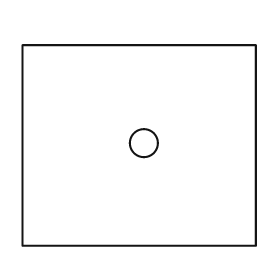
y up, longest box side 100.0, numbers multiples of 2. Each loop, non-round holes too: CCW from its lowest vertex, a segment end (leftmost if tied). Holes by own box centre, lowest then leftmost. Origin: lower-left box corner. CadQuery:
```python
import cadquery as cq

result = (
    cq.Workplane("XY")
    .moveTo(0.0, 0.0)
    .lineTo(100.0, 0.0)
    .lineTo(100.0, 86.0)
    .lineTo(0.0, 86.0)
    .close()
    .moveTo(52.0, 44.0)
    .circle(6.0)
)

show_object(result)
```